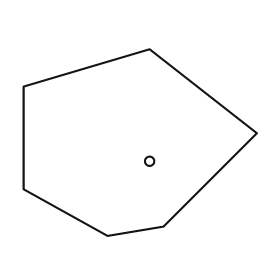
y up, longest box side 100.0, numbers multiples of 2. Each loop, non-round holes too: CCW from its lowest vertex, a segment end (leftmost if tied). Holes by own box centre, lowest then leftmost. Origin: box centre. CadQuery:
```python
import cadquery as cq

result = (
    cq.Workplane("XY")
    .moveTo(-14.0, -40.0)
    .lineTo(10.0, -36.0)
    .lineTo(50.0, 4.0)
    .lineTo(4.0, 40.0)
    .lineTo(-50.0, 24.0)
    .lineTo(-50.0, -20.0)
    .close()
    .moveTo(4.0, -8.0)
    .circle(2.0)
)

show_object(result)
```